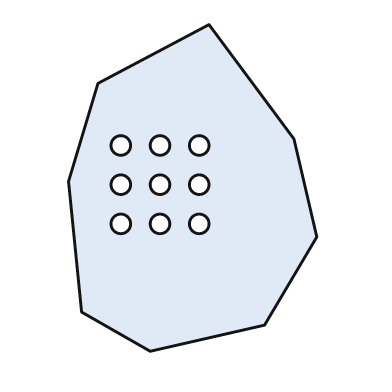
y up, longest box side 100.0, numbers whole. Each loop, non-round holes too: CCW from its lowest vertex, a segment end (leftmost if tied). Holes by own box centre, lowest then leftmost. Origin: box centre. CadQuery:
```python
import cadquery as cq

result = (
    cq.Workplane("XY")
    .moveTo(-13.0, -50.0)
    .lineTo(22.0, -42.0)
    .lineTo(38.0, -15.0)
    .lineTo(31.0, 15.0)
    .lineTo(5.0, 50.0)
    .lineTo(-29.0, 32.0)
    .lineTo(-38.0, 2.0)
    .lineTo(-34.0, -38.0)
    .close()
    .moveTo(-22.0, -11.0)
    .circle(3.0)
    .moveTo(-10.0, -11.0)
    .circle(3.0)
    .moveTo(2.0, -11.0)
    .circle(3.0)
    .moveTo(-22.0, 1.0)
    .circle(3.0)
    .moveTo(-10.0, 1.0)
    .circle(3.0)
    .moveTo(2.0, 1.0)
    .circle(3.0)
    .moveTo(-22.0, 13.0)
    .circle(3.0)
    .moveTo(-10.0, 13.0)
    .circle(3.0)
    .moveTo(2.0, 13.0)
    .circle(3.0)
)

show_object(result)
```